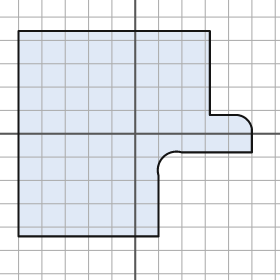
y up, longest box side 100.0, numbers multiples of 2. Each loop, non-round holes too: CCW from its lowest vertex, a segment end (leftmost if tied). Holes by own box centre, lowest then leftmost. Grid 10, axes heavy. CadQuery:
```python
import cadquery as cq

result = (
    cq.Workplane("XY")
    .moveTo(-50.0, -44.0)
    .lineTo(10.0, -44.0)
    .lineTo(10.0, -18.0)
    .threePointArc((12.0, -10.0), (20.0, -8.0))
    .lineTo(50.0, -8.0)
    .lineTo(50.0, 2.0)
    .threePointArc((48.0, 6.0), (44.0, 8.0))
    .lineTo(32.0, 8.0)
    .lineTo(32.0, 44.0)
    .lineTo(-50.0, 44.0)
    .close()
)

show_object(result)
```